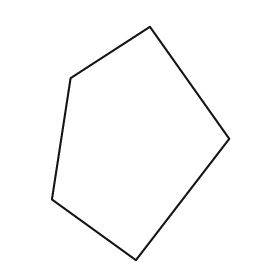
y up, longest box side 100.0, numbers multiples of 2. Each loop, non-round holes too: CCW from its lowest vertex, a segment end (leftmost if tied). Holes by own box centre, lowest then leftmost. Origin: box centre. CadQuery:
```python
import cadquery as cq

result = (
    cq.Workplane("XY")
    .moveTo(-2.0, -50.0)
    .lineTo(38.0, 2.0)
    .lineTo(4.0, 50.0)
    .lineTo(-30.0, 28.0)
    .lineTo(-38.0, -24.0)
    .close()
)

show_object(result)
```